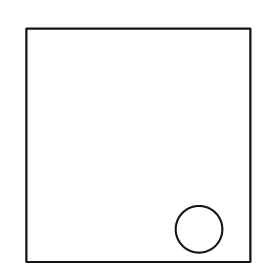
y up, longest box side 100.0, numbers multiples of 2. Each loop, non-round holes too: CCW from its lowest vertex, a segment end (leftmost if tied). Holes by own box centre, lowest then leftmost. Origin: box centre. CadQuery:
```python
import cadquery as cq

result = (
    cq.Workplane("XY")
    .moveTo(-48.0, -50.0)
    .lineTo(48.0, -50.0)
    .lineTo(48.0, 50.0)
    .lineTo(-48.0, 50.0)
    .close()
    .moveTo(26.0, -36.0)
    .circle(10.0)
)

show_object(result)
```